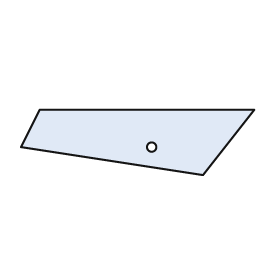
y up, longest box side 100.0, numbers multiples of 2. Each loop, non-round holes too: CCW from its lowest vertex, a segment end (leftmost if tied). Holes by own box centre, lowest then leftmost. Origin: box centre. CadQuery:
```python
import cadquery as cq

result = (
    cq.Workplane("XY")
    .moveTo(28.0, -14.0)
    .lineTo(50.0, 14.0)
    .lineTo(-42.0, 14.0)
    .lineTo(-50.0, -2.0)
    .close()
    .moveTo(6.0, -2.0)
    .circle(2.0)
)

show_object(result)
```